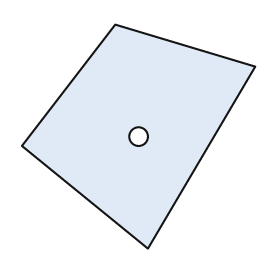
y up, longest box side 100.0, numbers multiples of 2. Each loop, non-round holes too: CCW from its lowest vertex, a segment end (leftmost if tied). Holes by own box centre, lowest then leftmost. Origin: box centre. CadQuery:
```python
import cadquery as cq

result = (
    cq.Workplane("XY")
    .moveTo(4.0, -48.0)
    .lineTo(50.0, 30.0)
    .lineTo(-10.0, 48.0)
    .lineTo(-50.0, -4.0)
    .close()
    .moveTo(0.0, 0.0)
    .circle(4.0)
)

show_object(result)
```